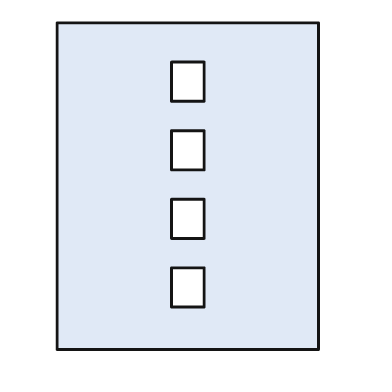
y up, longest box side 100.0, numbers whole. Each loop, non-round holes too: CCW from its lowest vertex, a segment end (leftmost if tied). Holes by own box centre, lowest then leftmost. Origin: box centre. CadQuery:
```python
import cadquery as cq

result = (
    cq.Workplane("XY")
    .moveTo(-40.0, -50.0)
    .lineTo(40.0, -50.0)
    .lineTo(40.0, 50.0)
    .lineTo(-40.0, 50.0)
    .close()
    .moveTo(-5.0, -37.0)
    .lineTo(5.0, -37.0)
    .lineTo(5.0, -25.0)
    .lineTo(-5.0, -25.0)
    .close()
    .moveTo(-5.0, -16.0)
    .lineTo(5.0, -16.0)
    .lineTo(5.0, -4.0)
    .lineTo(-5.0, -4.0)
    .close()
    .moveTo(-5.0, 5.0)
    .lineTo(5.0, 5.0)
    .lineTo(5.0, 17.0)
    .lineTo(-5.0, 17.0)
    .close()
    .moveTo(-5.0, 26.0)
    .lineTo(5.0, 26.0)
    .lineTo(5.0, 38.0)
    .lineTo(-5.0, 38.0)
    .close()
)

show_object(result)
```